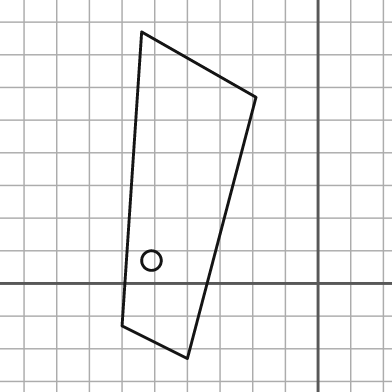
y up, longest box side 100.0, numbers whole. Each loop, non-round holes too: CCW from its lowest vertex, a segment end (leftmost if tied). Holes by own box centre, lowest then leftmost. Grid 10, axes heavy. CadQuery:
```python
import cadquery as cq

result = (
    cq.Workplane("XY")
    .moveTo(-40.0, -23.0)
    .lineTo(-19.0, 57.0)
    .lineTo(-54.0, 77.0)
    .lineTo(-60.0, -13.0)
    .close()
    .moveTo(-51.0, 7.0)
    .circle(3.0)
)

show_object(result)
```